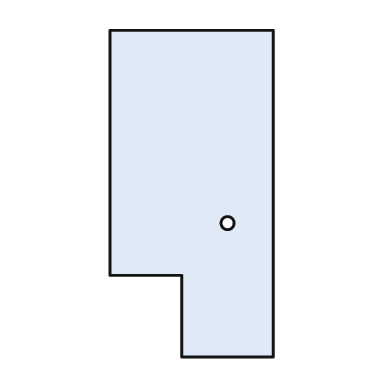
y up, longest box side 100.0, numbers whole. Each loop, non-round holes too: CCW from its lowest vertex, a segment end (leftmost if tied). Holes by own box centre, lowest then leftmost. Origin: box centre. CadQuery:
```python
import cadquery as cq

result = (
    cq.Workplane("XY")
    .moveTo(-3.0, -50.0)
    .lineTo(25.0, -50.0)
    .lineTo(25.0, 50.0)
    .lineTo(-25.0, 50.0)
    .lineTo(-25.0, -25.0)
    .lineTo(-3.0, -25.0)
    .close()
    .moveTo(11.0, -9.0)
    .circle(2.0)
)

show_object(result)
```